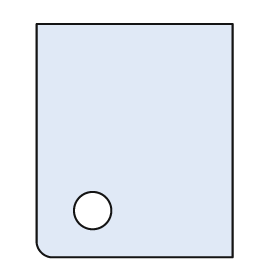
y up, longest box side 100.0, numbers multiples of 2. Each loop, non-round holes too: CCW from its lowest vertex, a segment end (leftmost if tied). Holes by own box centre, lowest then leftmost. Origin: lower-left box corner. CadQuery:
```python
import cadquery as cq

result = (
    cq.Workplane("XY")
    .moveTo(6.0, 0.0)
    .lineTo(84.0, 0.0)
    .lineTo(84.0, 100.0)
    .lineTo(0.0, 100.0)
    .lineTo(0.0, 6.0)
    .threePointArc((2.0, 2.0), (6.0, 0.0))
    .close()
    .moveTo(24.0, 20.0)
    .circle(8.0)
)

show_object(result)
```